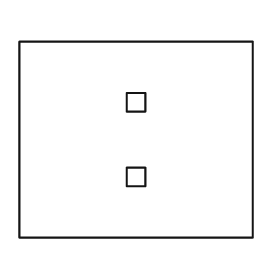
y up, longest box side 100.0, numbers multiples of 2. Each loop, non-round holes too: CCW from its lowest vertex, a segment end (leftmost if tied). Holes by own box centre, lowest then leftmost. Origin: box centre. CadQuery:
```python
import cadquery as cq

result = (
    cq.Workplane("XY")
    .moveTo(-50.0, -42.0)
    .lineTo(50.0, -42.0)
    .lineTo(50.0, 42.0)
    .lineTo(-50.0, 42.0)
    .close()
    .moveTo(-4.0, -20.0)
    .lineTo(4.0, -20.0)
    .lineTo(4.0, -12.0)
    .lineTo(-4.0, -12.0)
    .close()
    .moveTo(-4.0, 12.0)
    .lineTo(4.0, 12.0)
    .lineTo(4.0, 20.0)
    .lineTo(-4.0, 20.0)
    .close()
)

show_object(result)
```